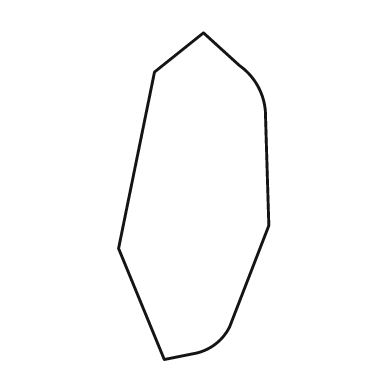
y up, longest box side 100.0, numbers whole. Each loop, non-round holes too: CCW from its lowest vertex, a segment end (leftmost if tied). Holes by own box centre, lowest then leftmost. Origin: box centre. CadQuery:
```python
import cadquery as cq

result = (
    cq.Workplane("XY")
    .moveTo(-9.0, -50.0)
    .lineTo(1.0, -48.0)
    .threePointArc((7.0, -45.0), (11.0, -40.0))
    .lineTo(23.0, -9.0)
    .lineTo(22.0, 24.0)
    .threePointArc((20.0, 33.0), (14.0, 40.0))
    .lineTo(3.0, 50.0)
    .lineTo(-12.0, 38.0)
    .lineTo(-23.0, -16.0)
    .close()
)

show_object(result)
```